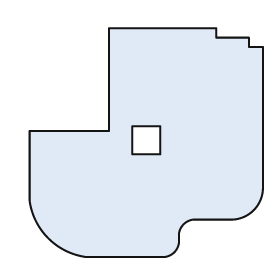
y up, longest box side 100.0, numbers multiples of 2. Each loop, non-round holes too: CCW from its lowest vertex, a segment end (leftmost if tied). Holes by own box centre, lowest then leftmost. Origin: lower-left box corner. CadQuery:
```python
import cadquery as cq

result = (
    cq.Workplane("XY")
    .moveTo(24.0, 0.0)
    .lineTo(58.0, 0.0)
    .threePointArc((62.0, 2.0), (64.0, 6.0))
    .lineTo(64.0, 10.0)
    .threePointArc((66.0, 14.0), (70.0, 16.0))
    .lineTo(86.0, 16.0)
    .threePointArc((96.0, 20.0), (100.0, 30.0))
    .lineTo(100.0, 90.0)
    .lineTo(94.0, 90.0)
    .lineTo(94.0, 94.0)
    .lineTo(80.0, 94.0)
    .lineTo(80.0, 98.0)
    .lineTo(34.0, 98.0)
    .lineTo(34.0, 54.0)
    .lineTo(0.0, 54.0)
    .lineTo(0.0, 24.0)
    .threePointArc((8.0, 8.0), (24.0, 0.0))
    .close()
    .moveTo(44.0, 44.0)
    .lineTo(56.0, 44.0)
    .lineTo(56.0, 56.0)
    .lineTo(44.0, 56.0)
    .close()
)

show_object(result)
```